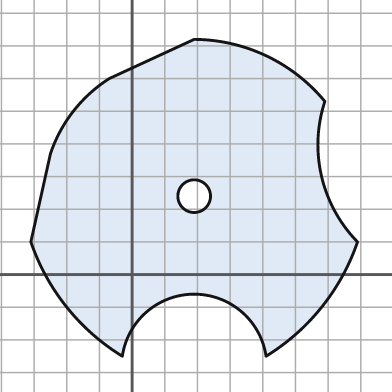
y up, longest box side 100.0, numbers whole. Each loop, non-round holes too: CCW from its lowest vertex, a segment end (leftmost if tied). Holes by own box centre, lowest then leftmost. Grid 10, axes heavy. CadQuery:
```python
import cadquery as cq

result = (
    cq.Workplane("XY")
    .moveTo(-3.0, -25.0)
    .threePointArc((19.0, -6.0), (41.0, -25.0))
    .threePointArc((58.0, -10.0), (69.0, 10.0))
    .threePointArc((58.0, 30.0), (59.0, 53.0))
    .threePointArc((41.0, 67.0), (19.0, 72.0))
    .lineTo(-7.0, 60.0)
    .threePointArc((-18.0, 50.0), (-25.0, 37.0))
    .lineTo(-31.0, 10.0)
    .threePointArc((-20.0, -10.0), (-3.0, -25.0))
    .close()
    .moveTo(19.0, 24.0)
    .circle(5.0)
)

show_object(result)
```